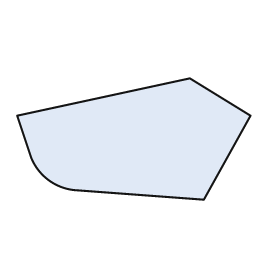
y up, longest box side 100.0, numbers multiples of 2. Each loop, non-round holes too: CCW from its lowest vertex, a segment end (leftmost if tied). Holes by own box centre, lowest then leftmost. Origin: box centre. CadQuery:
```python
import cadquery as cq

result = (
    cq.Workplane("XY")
    .moveTo(30.0, -26.0)
    .lineTo(50.0, 10.0)
    .lineTo(24.0, 26.0)
    .lineTo(-50.0, 10.0)
    .lineTo(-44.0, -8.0)
    .threePointArc((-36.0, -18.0), (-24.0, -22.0))
    .close()
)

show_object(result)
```